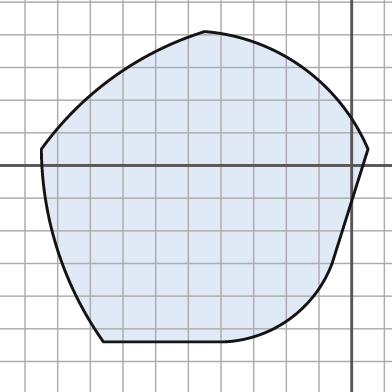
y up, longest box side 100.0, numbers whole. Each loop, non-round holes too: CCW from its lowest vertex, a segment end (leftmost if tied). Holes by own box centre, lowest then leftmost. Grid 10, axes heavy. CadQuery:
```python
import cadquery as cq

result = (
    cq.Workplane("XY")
    .moveTo(-76.0, -54.0)
    .lineTo(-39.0, -54.0)
    .threePointArc((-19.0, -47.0), (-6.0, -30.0))
    .lineTo(5.0, 5.0)
    .threePointArc((-15.0, 30.0), (-45.0, 41.0))
    .threePointArc((-73.0, 27.0), (-95.0, 5.0))
    .threePointArc((-90.0, -26.0), (-76.0, -54.0))
    .close()
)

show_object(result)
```